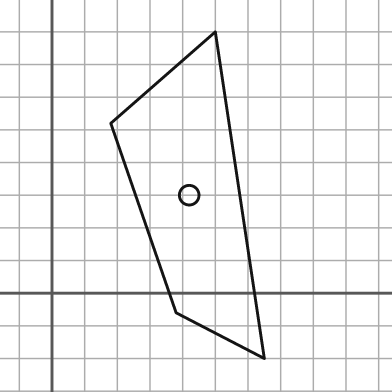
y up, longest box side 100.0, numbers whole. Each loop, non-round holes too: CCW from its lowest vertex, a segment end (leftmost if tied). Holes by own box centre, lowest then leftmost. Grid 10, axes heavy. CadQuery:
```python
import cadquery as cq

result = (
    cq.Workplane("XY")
    .moveTo(65.0, -20.0)
    .lineTo(50.0, 80.0)
    .lineTo(18.0, 52.0)
    .lineTo(38.0, -6.0)
    .close()
    .moveTo(42.0, 30.0)
    .circle(3.0)
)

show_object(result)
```